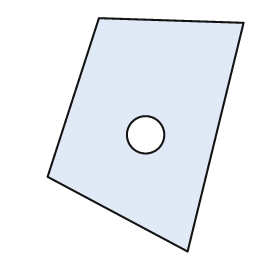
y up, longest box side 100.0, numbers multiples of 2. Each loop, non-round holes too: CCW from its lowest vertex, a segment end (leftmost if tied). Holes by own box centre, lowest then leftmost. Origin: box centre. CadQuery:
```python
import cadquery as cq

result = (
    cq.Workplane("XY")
    .moveTo(18.0, -50.0)
    .lineTo(42.0, 48.0)
    .lineTo(-20.0, 50.0)
    .lineTo(-42.0, -18.0)
    .close()
    .moveTo(0.0, 0.0)
    .circle(8.0)
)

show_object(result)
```